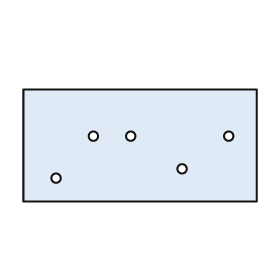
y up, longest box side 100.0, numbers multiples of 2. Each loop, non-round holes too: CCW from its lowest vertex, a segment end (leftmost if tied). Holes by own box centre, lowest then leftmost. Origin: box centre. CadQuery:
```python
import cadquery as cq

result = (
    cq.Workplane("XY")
    .moveTo(-50.0, -24.0)
    .lineTo(50.0, -24.0)
    .lineTo(50.0, 24.0)
    .lineTo(-50.0, 24.0)
    .close()
    .moveTo(-36.0, -14.0)
    .circle(2.0)
    .moveTo(18.0, -10.0)
    .circle(2.0)
    .moveTo(-20.0, 4.0)
    .circle(2.0)
    .moveTo(-4.0, 4.0)
    .circle(2.0)
    .moveTo(38.0, 4.0)
    .circle(2.0)
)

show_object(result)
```